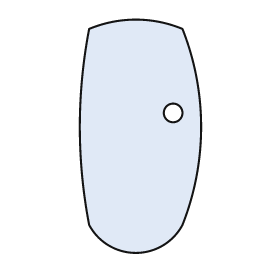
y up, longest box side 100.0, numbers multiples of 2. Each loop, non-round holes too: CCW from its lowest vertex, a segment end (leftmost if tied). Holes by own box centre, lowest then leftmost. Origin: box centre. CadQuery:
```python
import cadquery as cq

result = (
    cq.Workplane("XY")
    .moveTo(-22.0, -38.0)
    .threePointArc((-2.0, -50.0), (18.0, -38.0))
    .threePointArc((26.0, 4.0), (18.0, 46.0))
    .threePointArc((-2.0, 50.0), (-22.0, 46.0))
    .threePointArc((-26.0, 4.0), (-22.0, -38.0))
    .close()
    .moveTo(14.0, 10.0)
    .circle(4.0)
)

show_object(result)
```